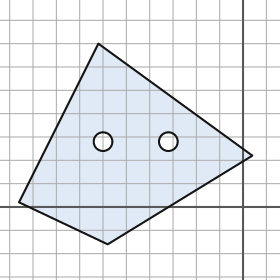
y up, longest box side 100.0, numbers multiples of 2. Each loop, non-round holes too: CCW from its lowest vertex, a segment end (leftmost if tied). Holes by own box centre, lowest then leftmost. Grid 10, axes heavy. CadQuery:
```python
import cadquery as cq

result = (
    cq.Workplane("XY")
    .moveTo(-58.0, -16.0)
    .lineTo(4.0, 22.0)
    .lineTo(-62.0, 70.0)
    .lineTo(-96.0, 2.0)
    .close()
    .moveTo(-60.0, 28.0)
    .circle(4.0)
    .moveTo(-32.0, 28.0)
    .circle(4.0)
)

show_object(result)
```